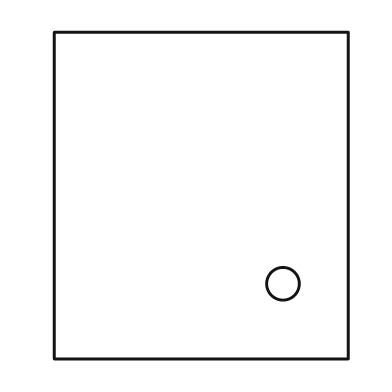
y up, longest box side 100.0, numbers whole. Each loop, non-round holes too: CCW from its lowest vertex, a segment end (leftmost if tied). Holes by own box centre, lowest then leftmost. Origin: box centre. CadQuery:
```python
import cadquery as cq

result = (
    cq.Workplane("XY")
    .moveTo(-45.0, -50.0)
    .lineTo(45.0, -50.0)
    .lineTo(45.0, 50.0)
    .lineTo(-45.0, 50.0)
    .close()
    .moveTo(25.0, -27.0)
    .circle(5.0)
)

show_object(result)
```